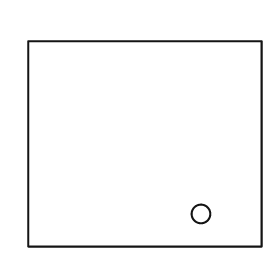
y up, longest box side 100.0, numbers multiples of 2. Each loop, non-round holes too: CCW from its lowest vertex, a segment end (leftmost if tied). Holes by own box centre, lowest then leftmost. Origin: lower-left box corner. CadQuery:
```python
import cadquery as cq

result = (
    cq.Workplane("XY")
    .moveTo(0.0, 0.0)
    .lineTo(100.0, 0.0)
    .lineTo(100.0, 88.0)
    .lineTo(0.0, 88.0)
    .close()
    .moveTo(74.0, 14.0)
    .circle(4.0)
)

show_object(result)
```